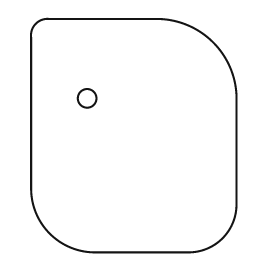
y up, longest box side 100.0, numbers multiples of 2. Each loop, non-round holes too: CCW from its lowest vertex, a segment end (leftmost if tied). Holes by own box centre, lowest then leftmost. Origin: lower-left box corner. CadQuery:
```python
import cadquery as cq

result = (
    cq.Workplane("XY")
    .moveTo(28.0, 0.0)
    .lineTo(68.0, 0.0)
    .threePointArc((82.0, 6.0), (88.0, 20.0))
    .lineTo(88.0, 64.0)
    .threePointArc((78.0, 90.0), (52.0, 100.0))
    .lineTo(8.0, 100.0)
    .threePointArc((2.0, 98.0), (0.0, 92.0))
    .lineTo(0.0, 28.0)
    .threePointArc((8.0, 8.0), (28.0, 0.0))
    .close()
    .moveTo(24.0, 66.0)
    .circle(4.0)
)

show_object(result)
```